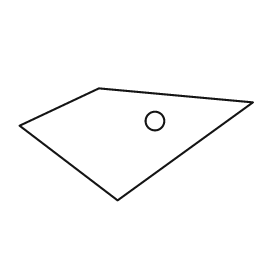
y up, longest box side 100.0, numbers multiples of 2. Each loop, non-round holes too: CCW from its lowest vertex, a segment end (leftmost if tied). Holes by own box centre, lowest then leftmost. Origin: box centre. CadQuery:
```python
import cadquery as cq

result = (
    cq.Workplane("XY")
    .moveTo(-8.0, -24.0)
    .lineTo(50.0, 18.0)
    .lineTo(-16.0, 24.0)
    .lineTo(-50.0, 8.0)
    .close()
    .moveTo(8.0, 10.0)
    .circle(4.0)
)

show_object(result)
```